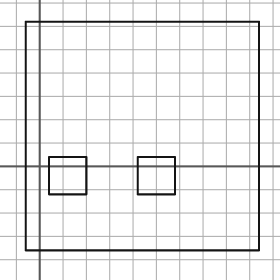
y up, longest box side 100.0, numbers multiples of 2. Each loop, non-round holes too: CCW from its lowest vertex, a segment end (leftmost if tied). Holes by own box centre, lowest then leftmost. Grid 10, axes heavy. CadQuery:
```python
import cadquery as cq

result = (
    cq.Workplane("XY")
    .moveTo(-6.0, -36.0)
    .lineTo(94.0, -36.0)
    .lineTo(94.0, 62.0)
    .lineTo(-6.0, 62.0)
    .close()
    .moveTo(4.0, -12.0)
    .lineTo(20.0, -12.0)
    .lineTo(20.0, 4.0)
    .lineTo(4.0, 4.0)
    .close()
    .moveTo(42.0, -12.0)
    .lineTo(58.0, -12.0)
    .lineTo(58.0, 4.0)
    .lineTo(42.0, 4.0)
    .close()
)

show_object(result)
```